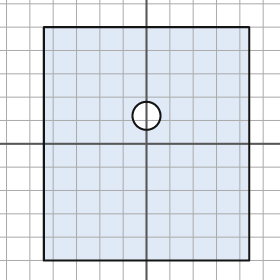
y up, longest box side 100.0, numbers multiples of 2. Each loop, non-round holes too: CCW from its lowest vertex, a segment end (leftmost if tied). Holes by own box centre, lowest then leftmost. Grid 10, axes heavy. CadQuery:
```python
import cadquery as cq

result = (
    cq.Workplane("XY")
    .moveTo(-44.0, -50.0)
    .lineTo(44.0, -50.0)
    .lineTo(44.0, 50.0)
    .lineTo(-44.0, 50.0)
    .close()
    .moveTo(0.0, 12.0)
    .circle(6.0)
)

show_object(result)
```